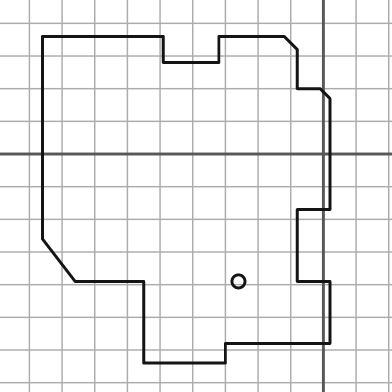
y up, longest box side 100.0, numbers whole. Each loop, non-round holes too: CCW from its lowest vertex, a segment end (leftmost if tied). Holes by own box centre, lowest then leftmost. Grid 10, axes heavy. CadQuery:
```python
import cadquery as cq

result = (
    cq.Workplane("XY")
    .moveTo(-55.0, -64.0)
    .lineTo(-30.0, -64.0)
    .lineTo(-30.0, -58.0)
    .lineTo(2.0, -58.0)
    .lineTo(2.0, -39.0)
    .lineTo(-8.0, -39.0)
    .lineTo(-8.0, -17.0)
    .lineTo(2.0, -17.0)
    .lineTo(2.0, 17.0)
    .lineTo(-1.0, 20.0)
    .lineTo(-8.0, 20.0)
    .lineTo(-8.0, 32.0)
    .lineTo(-12.0, 36.0)
    .lineTo(-32.0, 36.0)
    .lineTo(-32.0, 28.0)
    .lineTo(-49.0, 28.0)
    .lineTo(-49.0, 36.0)
    .lineTo(-86.0, 36.0)
    .lineTo(-86.0, -26.0)
    .lineTo(-76.0, -39.0)
    .lineTo(-55.0, -39.0)
    .close()
    .moveTo(-26.0, -39.0)
    .circle(2.0)
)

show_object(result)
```